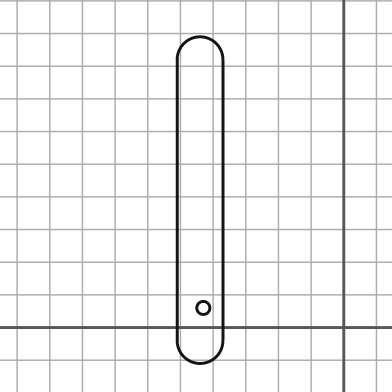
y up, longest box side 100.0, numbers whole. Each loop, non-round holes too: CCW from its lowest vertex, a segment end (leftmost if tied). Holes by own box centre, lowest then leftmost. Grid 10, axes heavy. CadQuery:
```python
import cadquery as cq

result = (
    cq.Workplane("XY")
    .moveTo(-51.0, -4.0)
    .threePointArc((-44.0, -11.0), (-37.0, -4.0))
    .lineTo(-37.0, 82.0)
    .threePointArc((-44.0, 89.0), (-51.0, 82.0))
    .close()
    .moveTo(-43.0, 6.0)
    .circle(2.0)
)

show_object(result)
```